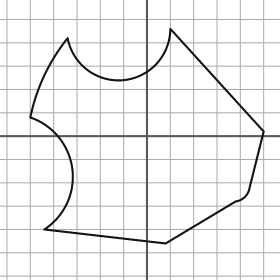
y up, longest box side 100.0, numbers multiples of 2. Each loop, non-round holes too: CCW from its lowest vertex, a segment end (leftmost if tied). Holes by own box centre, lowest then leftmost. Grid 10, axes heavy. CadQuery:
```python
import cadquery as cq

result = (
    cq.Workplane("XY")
    .moveTo(8.0, -46.0)
    .lineTo(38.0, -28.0)
    .threePointArc((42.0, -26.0), (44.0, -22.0))
    .lineTo(50.0, 2.0)
    .lineTo(10.0, 46.0)
    .threePointArc((-10.0, 24.0), (-34.0, 42.0))
    .threePointArc((-44.0, 26.0), (-50.0, 8.0))
    .threePointArc((-32.0, -14.0), (-44.0, -40.0))
    .close()
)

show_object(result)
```